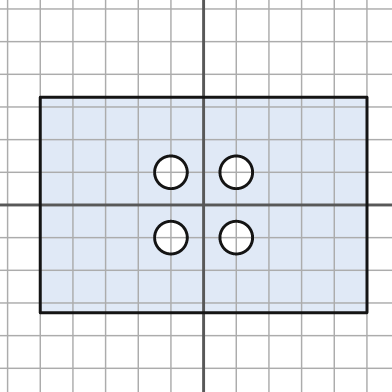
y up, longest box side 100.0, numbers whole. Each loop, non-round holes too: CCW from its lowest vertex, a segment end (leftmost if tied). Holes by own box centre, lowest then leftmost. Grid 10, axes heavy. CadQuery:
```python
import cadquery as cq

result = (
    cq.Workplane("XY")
    .moveTo(-50.0, -33.0)
    .lineTo(50.0, -33.0)
    .lineTo(50.0, 33.0)
    .lineTo(-50.0, 33.0)
    .close()
    .moveTo(-10.0, -10.0)
    .circle(5.0)
    .moveTo(10.0, -10.0)
    .circle(5.0)
    .moveTo(-10.0, 10.0)
    .circle(5.0)
    .moveTo(10.0, 10.0)
    .circle(5.0)
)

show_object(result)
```